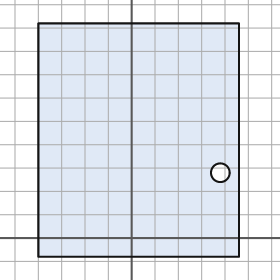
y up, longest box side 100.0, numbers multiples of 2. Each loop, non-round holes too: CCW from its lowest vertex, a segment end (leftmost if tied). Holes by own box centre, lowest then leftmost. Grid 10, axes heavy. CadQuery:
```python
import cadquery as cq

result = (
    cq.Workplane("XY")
    .moveTo(-40.0, -8.0)
    .lineTo(46.0, -8.0)
    .lineTo(46.0, 92.0)
    .lineTo(-40.0, 92.0)
    .close()
    .moveTo(38.0, 28.0)
    .circle(4.0)
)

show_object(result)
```